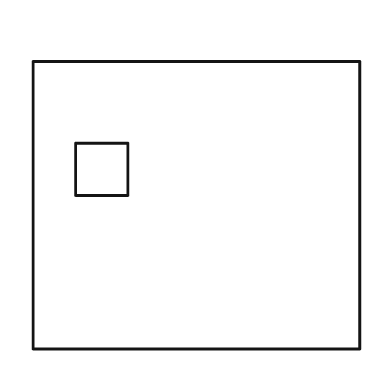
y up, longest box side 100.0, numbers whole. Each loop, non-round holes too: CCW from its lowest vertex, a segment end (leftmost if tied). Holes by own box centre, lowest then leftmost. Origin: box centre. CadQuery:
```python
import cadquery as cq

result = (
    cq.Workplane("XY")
    .moveTo(-50.0, -44.0)
    .lineTo(50.0, -44.0)
    .lineTo(50.0, 44.0)
    .lineTo(-50.0, 44.0)
    .close()
    .moveTo(-37.0, 3.0)
    .lineTo(-21.0, 3.0)
    .lineTo(-21.0, 19.0)
    .lineTo(-37.0, 19.0)
    .close()
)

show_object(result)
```